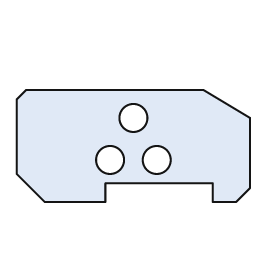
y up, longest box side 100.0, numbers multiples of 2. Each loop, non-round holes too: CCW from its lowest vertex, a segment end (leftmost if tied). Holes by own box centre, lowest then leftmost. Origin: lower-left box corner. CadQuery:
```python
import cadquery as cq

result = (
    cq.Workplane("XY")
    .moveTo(12.0, 0.0)
    .lineTo(38.0, 0.0)
    .lineTo(38.0, 8.0)
    .lineTo(84.0, 8.0)
    .lineTo(84.0, 0.0)
    .lineTo(94.0, 0.0)
    .lineTo(100.0, 6.0)
    .lineTo(100.0, 36.0)
    .lineTo(80.0, 48.0)
    .lineTo(4.0, 48.0)
    .lineTo(0.0, 44.0)
    .lineTo(0.0, 12.0)
    .close()
    .moveTo(40.0, 18.0)
    .circle(6.0)
    .moveTo(60.0, 18.0)
    .circle(6.0)
    .moveTo(50.0, 36.0)
    .circle(6.0)
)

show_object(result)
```